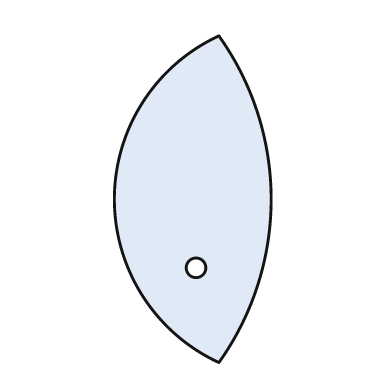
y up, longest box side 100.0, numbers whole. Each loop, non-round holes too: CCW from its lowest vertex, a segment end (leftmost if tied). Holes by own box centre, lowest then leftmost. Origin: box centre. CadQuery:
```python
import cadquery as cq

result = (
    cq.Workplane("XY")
    .moveTo(8.0, -50.0)
    .threePointArc((24.0, 0.0), (8.0, 50.0))
    .threePointArc((-24.0, 0.0), (8.0, -50.0))
    .close()
    .moveTo(1.0, -21.0)
    .circle(3.0)
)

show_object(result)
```